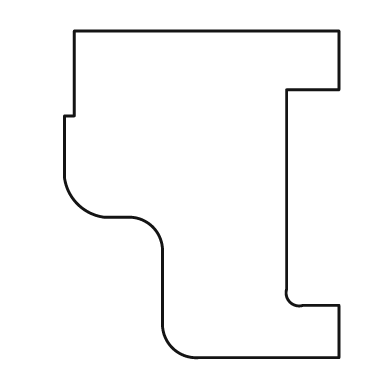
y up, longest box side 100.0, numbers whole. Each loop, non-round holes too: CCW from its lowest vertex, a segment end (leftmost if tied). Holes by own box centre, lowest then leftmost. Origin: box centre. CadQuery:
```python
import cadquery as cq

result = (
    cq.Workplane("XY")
    .moveTo(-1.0, -50.0)
    .lineTo(42.0, -50.0)
    .lineTo(42.0, -34.0)
    .lineTo(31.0, -34.0)
    .threePointArc((27.0, -33.0), (26.0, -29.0))
    .lineTo(26.0, 32.0)
    .lineTo(42.0, 32.0)
    .lineTo(42.0, 50.0)
    .lineTo(-39.0, 50.0)
    .lineTo(-39.0, 24.0)
    .lineTo(-42.0, 24.0)
    .lineTo(-42.0, 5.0)
    .threePointArc((-38.0, -3.0), (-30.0, -7.0))
    .lineTo(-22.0, -7.0)
    .threePointArc((-15.0, -10.0), (-12.0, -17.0))
    .lineTo(-12.0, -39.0)
    .threePointArc((-9.0, -47.0), (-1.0, -50.0))
    .close()
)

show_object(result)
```